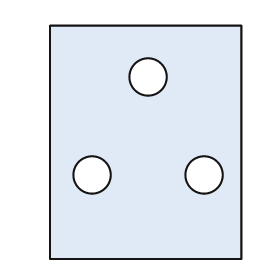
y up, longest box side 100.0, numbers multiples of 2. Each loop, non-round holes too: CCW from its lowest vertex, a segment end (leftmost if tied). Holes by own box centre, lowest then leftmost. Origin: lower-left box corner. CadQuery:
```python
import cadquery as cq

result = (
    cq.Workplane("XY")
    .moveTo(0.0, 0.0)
    .lineTo(82.0, 0.0)
    .lineTo(82.0, 100.0)
    .lineTo(0.0, 100.0)
    .close()
    .moveTo(18.0, 36.0)
    .circle(8.0)
    .moveTo(66.0, 36.0)
    .circle(8.0)
    .moveTo(42.0, 78.0)
    .circle(8.0)
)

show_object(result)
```